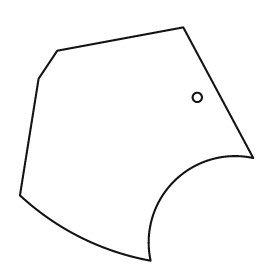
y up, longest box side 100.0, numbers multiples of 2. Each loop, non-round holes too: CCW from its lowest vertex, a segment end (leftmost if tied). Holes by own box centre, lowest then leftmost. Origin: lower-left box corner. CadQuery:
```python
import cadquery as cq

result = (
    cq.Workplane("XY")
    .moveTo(56.0, 0.0)
    .threePointArc((66.0, 34.0), (100.0, 44.0))
    .lineTo(70.0, 100.0)
    .lineTo(16.0, 90.0)
    .lineTo(8.0, 78.0)
    .lineTo(0.0, 28.0)
    .threePointArc((26.0, 10.0), (56.0, 0.0))
    .close()
    .moveTo(76.0, 70.0)
    .circle(2.0)
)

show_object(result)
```